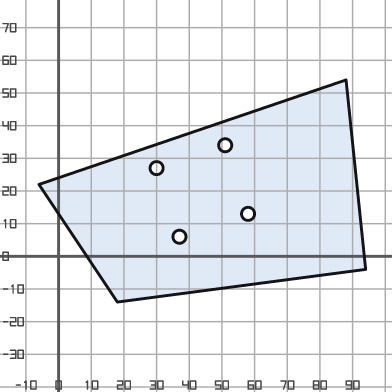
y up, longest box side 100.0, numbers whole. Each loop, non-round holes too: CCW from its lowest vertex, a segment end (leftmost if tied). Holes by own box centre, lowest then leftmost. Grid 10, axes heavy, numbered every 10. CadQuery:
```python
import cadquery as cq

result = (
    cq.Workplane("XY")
    .moveTo(18.0, -14.0)
    .lineTo(94.0, -4.0)
    .lineTo(88.0, 54.0)
    .lineTo(-6.0, 22.0)
    .close()
    .moveTo(37.0, 6.0)
    .circle(2.0)
    .moveTo(58.0, 13.0)
    .circle(2.0)
    .moveTo(30.0, 27.0)
    .circle(2.0)
    .moveTo(51.0, 34.0)
    .circle(2.0)
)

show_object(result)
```